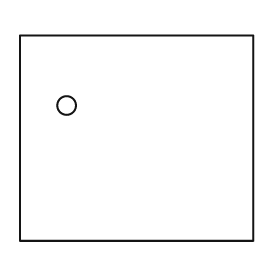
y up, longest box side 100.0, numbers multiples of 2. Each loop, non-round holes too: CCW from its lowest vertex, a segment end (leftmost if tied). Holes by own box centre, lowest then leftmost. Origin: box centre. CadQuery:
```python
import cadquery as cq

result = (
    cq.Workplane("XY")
    .moveTo(-50.0, -44.0)
    .lineTo(50.0, -44.0)
    .lineTo(50.0, 44.0)
    .lineTo(-50.0, 44.0)
    .close()
    .moveTo(-30.0, 14.0)
    .circle(4.0)
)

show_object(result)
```